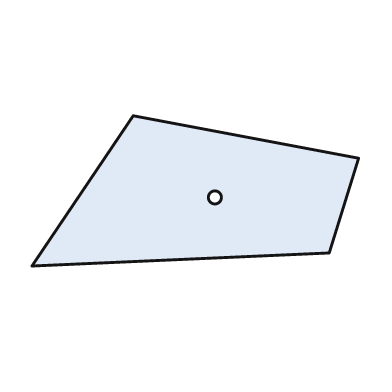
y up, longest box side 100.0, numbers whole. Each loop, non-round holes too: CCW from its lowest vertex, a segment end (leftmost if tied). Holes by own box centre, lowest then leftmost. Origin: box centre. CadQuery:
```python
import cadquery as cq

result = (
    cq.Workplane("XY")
    .moveTo(-50.0, -23.0)
    .lineTo(41.0, -19.0)
    .lineTo(50.0, 10.0)
    .lineTo(-19.0, 23.0)
    .close()
    .moveTo(6.0, -2.0)
    .circle(2.0)
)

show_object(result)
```